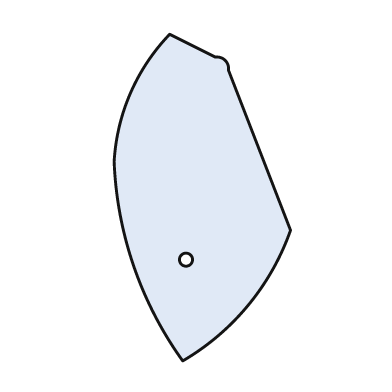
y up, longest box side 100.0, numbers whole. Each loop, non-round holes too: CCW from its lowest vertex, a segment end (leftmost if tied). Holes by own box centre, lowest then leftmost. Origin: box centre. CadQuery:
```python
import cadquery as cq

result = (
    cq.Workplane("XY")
    .moveTo(-6.0, -50.0)
    .threePointArc((14.0, -33.0), (27.0, -10.0))
    .lineTo(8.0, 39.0)
    .threePointArc((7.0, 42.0), (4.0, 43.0))
    .lineTo(-10.0, 50.0)
    .threePointArc((-22.0, 32.0), (-27.0, 11.0))
    .threePointArc((-21.0, -21.0), (-6.0, -50.0))
    .close()
    .moveTo(-5.0, -19.0)
    .circle(2.0)
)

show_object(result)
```